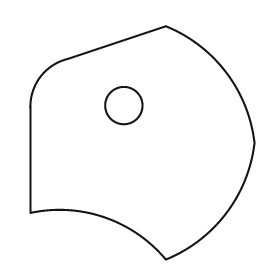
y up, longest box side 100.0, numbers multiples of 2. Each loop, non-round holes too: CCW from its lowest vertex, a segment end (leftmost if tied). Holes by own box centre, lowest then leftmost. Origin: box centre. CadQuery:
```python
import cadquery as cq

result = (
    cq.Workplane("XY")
    .moveTo(10.0, -50.0)
    .threePointArc((36.0, -30.0), (48.0, 0.0))
    .threePointArc((36.0, 30.0), (10.0, 50.0))
    .lineTo(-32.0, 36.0)
    .threePointArc((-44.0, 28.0), (-48.0, 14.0))
    .lineTo(-48.0, -30.0)
    .threePointArc((-16.0, -32.0), (10.0, -50.0))
    .close()
    .moveTo(-8.0, 16.0)
    .circle(8.0)
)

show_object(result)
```